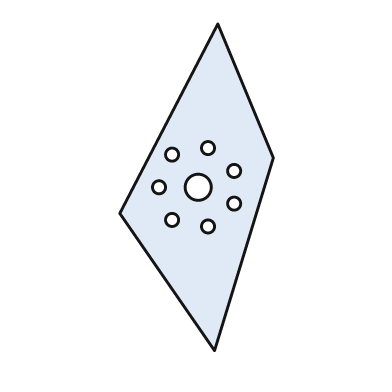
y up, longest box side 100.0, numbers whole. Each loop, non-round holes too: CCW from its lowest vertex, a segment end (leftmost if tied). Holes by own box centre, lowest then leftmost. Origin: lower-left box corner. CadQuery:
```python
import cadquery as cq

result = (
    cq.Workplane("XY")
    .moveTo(29.0, 0.0)
    .lineTo(47.0, 59.0)
    .lineTo(30.0, 100.0)
    .lineTo(0.0, 42.0)
    .close()
    .moveTo(27.0, 38.0)
    .circle(2.0)
    .moveTo(16.0, 40.0)
    .circle(2.0)
    .moveTo(35.0, 45.0)
    .circle(2.0)
    .moveTo(12.0, 50.0)
    .circle(2.0)
    .moveTo(24.0, 50.0)
    .circle(4.0)
    .moveTo(35.0, 55.0)
    .circle(2.0)
    .moveTo(16.0, 60.0)
    .circle(2.0)
    .moveTo(27.0, 62.0)
    .circle(2.0)
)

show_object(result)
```